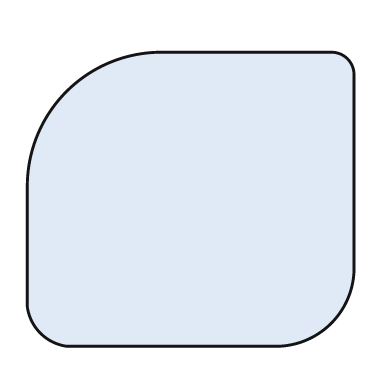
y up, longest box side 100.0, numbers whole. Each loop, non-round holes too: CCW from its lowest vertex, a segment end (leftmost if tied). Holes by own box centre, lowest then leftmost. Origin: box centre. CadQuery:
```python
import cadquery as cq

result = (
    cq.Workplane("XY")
    .moveTo(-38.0, -45.0)
    .lineTo(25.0, -45.0)
    .threePointArc((43.0, -38.0), (50.0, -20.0))
    .lineTo(50.0, 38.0)
    .threePointArc((48.0, 43.0), (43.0, 45.0))
    .lineTo(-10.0, 45.0)
    .threePointArc((-38.0, 33.0), (-50.0, 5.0))
    .lineTo(-50.0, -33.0)
    .threePointArc((-46.0, -41.0), (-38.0, -45.0))
    .close()
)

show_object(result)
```